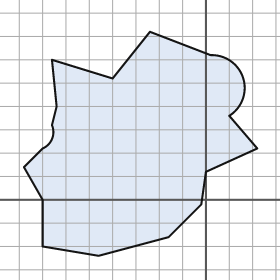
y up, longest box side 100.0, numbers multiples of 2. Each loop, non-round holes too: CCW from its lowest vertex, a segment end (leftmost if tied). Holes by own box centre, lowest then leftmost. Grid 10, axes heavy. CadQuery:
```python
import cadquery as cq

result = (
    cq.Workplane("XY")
    .moveTo(-46.0, -24.0)
    .lineTo(-16.0, -16.0)
    .lineTo(-2.0, -2.0)
    .lineTo(0.0, 12.0)
    .lineTo(22.0, 22.0)
    .lineTo(10.0, 36.0)
    .threePointArc((16.0, 52.0), (2.0, 62.0))
    .lineTo(-24.0, 72.0)
    .lineTo(-40.0, 52.0)
    .lineTo(-66.0, 60.0)
    .lineTo(-64.0, 40.0)
    .lineTo(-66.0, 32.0)
    .threePointArc((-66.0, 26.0), (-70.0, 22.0))
    .lineTo(-78.0, 14.0)
    .lineTo(-70.0, 0.0)
    .lineTo(-70.0, -20.0)
    .close()
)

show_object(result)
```